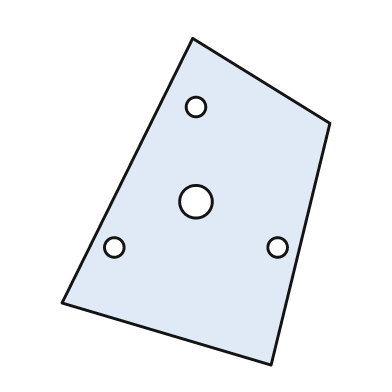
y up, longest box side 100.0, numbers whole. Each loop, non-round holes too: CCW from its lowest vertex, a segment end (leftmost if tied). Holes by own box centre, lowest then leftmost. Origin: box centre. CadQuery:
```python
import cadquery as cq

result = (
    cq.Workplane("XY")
    .moveTo(23.0, -50.0)
    .lineTo(41.0, 24.0)
    .lineTo(-1.0, 50.0)
    .lineTo(-41.0, -31.0)
    .close()
    .moveTo(-25.0, -14.0)
    .circle(3.0)
    .moveTo(25.0, -14.0)
    .circle(3.0)
    .moveTo(0.0, 0.0)
    .circle(5.0)
    .moveTo(0.0, 29.0)
    .circle(3.0)
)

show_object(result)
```